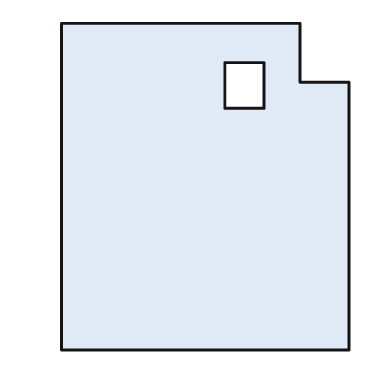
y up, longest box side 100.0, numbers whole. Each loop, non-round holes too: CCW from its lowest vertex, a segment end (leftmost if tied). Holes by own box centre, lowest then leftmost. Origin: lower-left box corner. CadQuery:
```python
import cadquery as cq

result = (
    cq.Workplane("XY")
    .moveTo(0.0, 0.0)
    .lineTo(88.0, 0.0)
    .lineTo(88.0, 82.0)
    .lineTo(73.0, 82.0)
    .lineTo(73.0, 100.0)
    .lineTo(0.0, 100.0)
    .close()
    .moveTo(50.0, 74.0)
    .lineTo(62.0, 74.0)
    .lineTo(62.0, 88.0)
    .lineTo(50.0, 88.0)
    .close()
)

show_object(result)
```